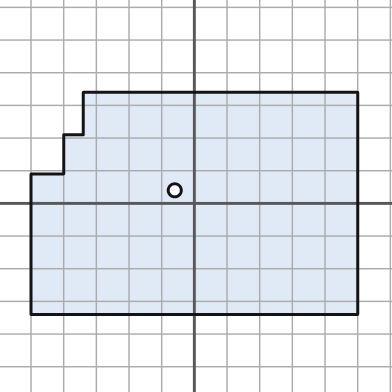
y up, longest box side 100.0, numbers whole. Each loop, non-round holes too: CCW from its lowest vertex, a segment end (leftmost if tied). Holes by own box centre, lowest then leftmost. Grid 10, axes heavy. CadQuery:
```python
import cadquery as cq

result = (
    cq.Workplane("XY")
    .moveTo(-50.0, -34.0)
    .lineTo(50.0, -34.0)
    .lineTo(50.0, 34.0)
    .lineTo(-34.0, 34.0)
    .lineTo(-34.0, 21.0)
    .lineTo(-40.0, 21.0)
    .lineTo(-40.0, 9.0)
    .lineTo(-50.0, 9.0)
    .close()
    .moveTo(-6.0, 4.0)
    .circle(2.0)
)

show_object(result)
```